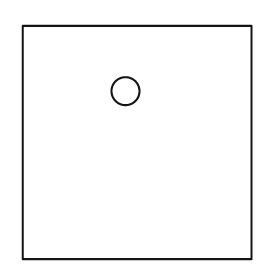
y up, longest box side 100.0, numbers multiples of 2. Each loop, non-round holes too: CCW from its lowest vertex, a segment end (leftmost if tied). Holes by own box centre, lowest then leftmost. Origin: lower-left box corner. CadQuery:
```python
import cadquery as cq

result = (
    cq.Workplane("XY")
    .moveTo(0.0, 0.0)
    .lineTo(98.0, 0.0)
    .lineTo(98.0, 100.0)
    .lineTo(0.0, 100.0)
    .close()
    .moveTo(44.0, 72.0)
    .circle(6.0)
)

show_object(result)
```